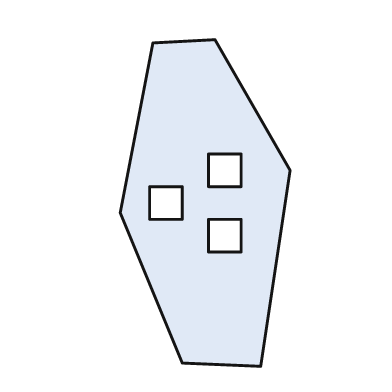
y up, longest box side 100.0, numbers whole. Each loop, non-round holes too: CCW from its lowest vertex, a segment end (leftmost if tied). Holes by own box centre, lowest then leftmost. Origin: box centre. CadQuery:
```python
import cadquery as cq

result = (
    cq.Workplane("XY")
    .moveTo(17.0, -50.0)
    .lineTo(26.0, 10.0)
    .lineTo(3.0, 50.0)
    .lineTo(-16.0, 49.0)
    .lineTo(-26.0, -3.0)
    .lineTo(-7.0, -49.0)
    .close()
    .moveTo(1.0, -15.0)
    .lineTo(11.0, -15.0)
    .lineTo(11.0, -5.0)
    .lineTo(1.0, -5.0)
    .close()
    .moveTo(-17.0, -5.0)
    .lineTo(-7.0, -5.0)
    .lineTo(-7.0, 5.0)
    .lineTo(-17.0, 5.0)
    .close()
    .moveTo(1.0, 5.0)
    .lineTo(11.0, 5.0)
    .lineTo(11.0, 15.0)
    .lineTo(1.0, 15.0)
    .close()
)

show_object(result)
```